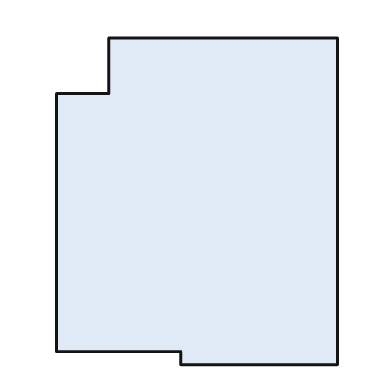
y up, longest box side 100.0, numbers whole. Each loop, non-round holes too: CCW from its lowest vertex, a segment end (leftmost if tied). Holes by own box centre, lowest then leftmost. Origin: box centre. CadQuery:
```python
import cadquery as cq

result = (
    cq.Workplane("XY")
    .moveTo(-5.0, -50.0)
    .lineTo(43.0, -50.0)
    .lineTo(43.0, 50.0)
    .lineTo(-27.0, 50.0)
    .lineTo(-27.0, 33.0)
    .lineTo(-43.0, 33.0)
    .lineTo(-43.0, -46.0)
    .lineTo(-5.0, -46.0)
    .close()
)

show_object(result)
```